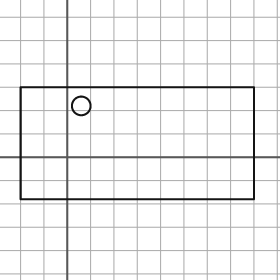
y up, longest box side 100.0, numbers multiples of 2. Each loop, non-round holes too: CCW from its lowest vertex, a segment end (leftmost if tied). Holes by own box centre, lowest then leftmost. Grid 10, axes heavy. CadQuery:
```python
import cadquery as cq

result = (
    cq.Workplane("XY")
    .moveTo(-20.0, -18.0)
    .lineTo(80.0, -18.0)
    .lineTo(80.0, 30.0)
    .lineTo(-20.0, 30.0)
    .close()
    .moveTo(6.0, 22.0)
    .circle(4.0)
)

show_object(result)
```